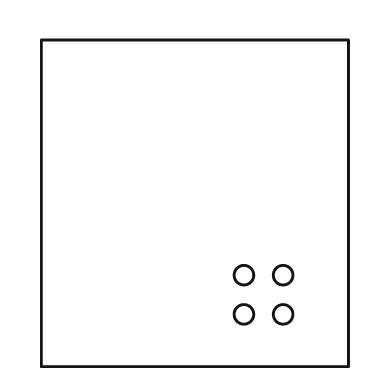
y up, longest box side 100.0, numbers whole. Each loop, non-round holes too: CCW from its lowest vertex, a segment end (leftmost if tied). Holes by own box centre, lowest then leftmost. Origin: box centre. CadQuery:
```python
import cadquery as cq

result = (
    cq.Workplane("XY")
    .moveTo(-47.0, -50.0)
    .lineTo(47.0, -50.0)
    .lineTo(47.0, 50.0)
    .lineTo(-47.0, 50.0)
    .close()
    .moveTo(15.0, -34.0)
    .circle(3.0)
    .moveTo(27.0, -34.0)
    .circle(3.0)
    .moveTo(15.0, -22.0)
    .circle(3.0)
    .moveTo(27.0, -22.0)
    .circle(3.0)
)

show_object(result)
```